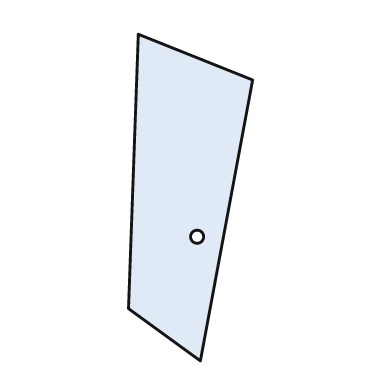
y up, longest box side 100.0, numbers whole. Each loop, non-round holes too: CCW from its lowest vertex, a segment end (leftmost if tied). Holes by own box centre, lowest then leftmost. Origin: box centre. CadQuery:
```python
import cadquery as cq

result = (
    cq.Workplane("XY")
    .moveTo(3.0, -50.0)
    .lineTo(19.0, 36.0)
    .lineTo(-16.0, 50.0)
    .lineTo(-19.0, -34.0)
    .close()
    .moveTo(2.0, -12.0)
    .circle(2.0)
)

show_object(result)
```